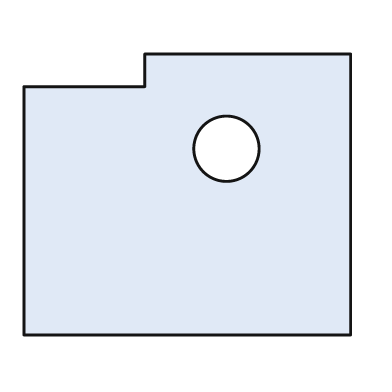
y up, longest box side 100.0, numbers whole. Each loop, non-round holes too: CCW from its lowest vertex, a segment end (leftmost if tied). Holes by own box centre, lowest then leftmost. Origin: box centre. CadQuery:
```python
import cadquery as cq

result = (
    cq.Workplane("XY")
    .moveTo(-50.0, -43.0)
    .lineTo(50.0, -43.0)
    .lineTo(50.0, 43.0)
    .lineTo(-13.0, 43.0)
    .lineTo(-13.0, 33.0)
    .lineTo(-50.0, 33.0)
    .close()
    .moveTo(12.0, 14.0)
    .circle(10.0)
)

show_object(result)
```